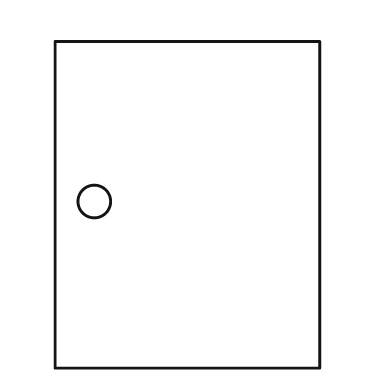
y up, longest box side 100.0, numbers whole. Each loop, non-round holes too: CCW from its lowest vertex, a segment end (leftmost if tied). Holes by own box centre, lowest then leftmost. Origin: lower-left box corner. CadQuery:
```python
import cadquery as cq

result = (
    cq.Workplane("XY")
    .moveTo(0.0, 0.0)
    .lineTo(81.0, 0.0)
    .lineTo(81.0, 100.0)
    .lineTo(0.0, 100.0)
    .close()
    .moveTo(12.0, 51.0)
    .circle(5.0)
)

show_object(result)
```